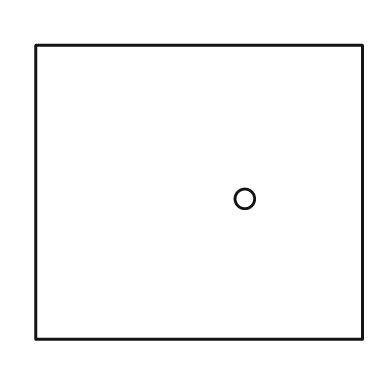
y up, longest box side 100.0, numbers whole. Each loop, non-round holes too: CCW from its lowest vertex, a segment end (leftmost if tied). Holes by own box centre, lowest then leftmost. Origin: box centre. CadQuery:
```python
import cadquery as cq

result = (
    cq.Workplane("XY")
    .moveTo(-50.0, -45.0)
    .lineTo(50.0, -45.0)
    .lineTo(50.0, 45.0)
    .lineTo(-50.0, 45.0)
    .close()
    .moveTo(14.0, -2.0)
    .circle(3.0)
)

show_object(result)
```